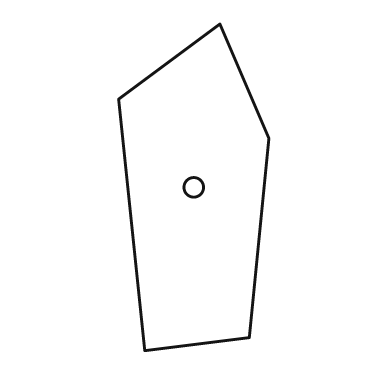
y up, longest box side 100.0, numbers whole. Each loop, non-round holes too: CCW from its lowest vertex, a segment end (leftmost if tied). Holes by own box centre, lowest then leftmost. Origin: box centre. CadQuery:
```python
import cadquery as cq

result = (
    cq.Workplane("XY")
    .moveTo(-15.0, -50.0)
    .lineTo(17.0, -46.0)
    .lineTo(23.0, 15.0)
    .lineTo(8.0, 50.0)
    .lineTo(-23.0, 27.0)
    .close()
    .moveTo(0.0, 0.0)
    .circle(3.0)
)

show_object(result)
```